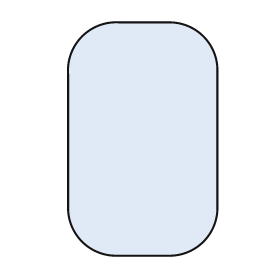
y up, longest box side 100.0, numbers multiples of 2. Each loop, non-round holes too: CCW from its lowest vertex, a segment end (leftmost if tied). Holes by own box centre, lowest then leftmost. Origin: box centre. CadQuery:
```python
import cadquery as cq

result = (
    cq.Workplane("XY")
    .moveTo(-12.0, -50.0)
    .lineTo(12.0, -50.0)
    .threePointArc((26.0, -44.0), (32.0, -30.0))
    .lineTo(32.0, 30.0)
    .threePointArc((26.0, 44.0), (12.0, 50.0))
    .lineTo(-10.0, 50.0)
    .threePointArc((-26.0, 44.0), (-32.0, 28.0))
    .lineTo(-32.0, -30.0)
    .threePointArc((-26.0, -44.0), (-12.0, -50.0))
    .close()
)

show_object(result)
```